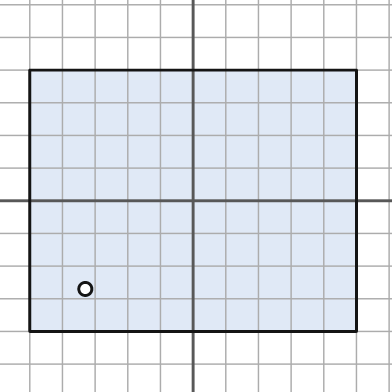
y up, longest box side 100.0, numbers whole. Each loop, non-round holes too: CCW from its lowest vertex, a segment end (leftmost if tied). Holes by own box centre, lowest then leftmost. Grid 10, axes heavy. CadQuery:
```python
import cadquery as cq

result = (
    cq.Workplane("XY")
    .moveTo(-50.0, -40.0)
    .lineTo(50.0, -40.0)
    .lineTo(50.0, 40.0)
    .lineTo(-50.0, 40.0)
    .close()
    .moveTo(-33.0, -27.0)
    .circle(2.0)
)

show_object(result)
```